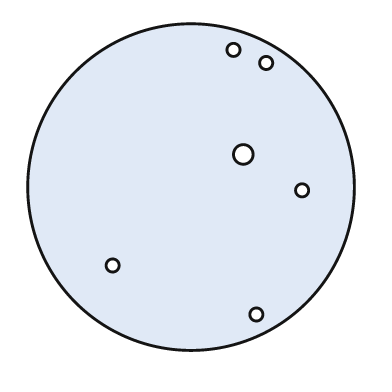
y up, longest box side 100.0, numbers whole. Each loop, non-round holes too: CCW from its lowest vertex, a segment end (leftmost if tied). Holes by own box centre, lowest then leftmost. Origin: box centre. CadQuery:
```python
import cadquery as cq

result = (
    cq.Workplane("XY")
    .moveTo(0.0, 0.0)
    .circle(50.0)
    .moveTo(20.0, -39.0)
    .circle(2.0)
    .moveTo(-24.0, -24.0)
    .circle(2.0)
    .moveTo(34.0, -1.0)
    .circle(2.0)
    .moveTo(16.0, 10.0)
    .circle(3.0)
    .moveTo(23.0, 38.0)
    .circle(2.0)
    .moveTo(13.0, 42.0)
    .circle(2.0)
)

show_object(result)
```